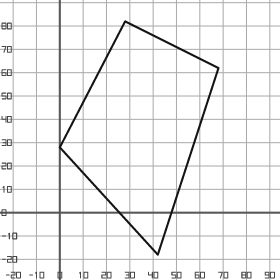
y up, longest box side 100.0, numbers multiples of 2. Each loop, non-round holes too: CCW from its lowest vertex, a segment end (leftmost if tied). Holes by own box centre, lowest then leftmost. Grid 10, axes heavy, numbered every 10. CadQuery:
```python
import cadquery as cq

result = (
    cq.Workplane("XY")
    .moveTo(42.0, -18.0)
    .lineTo(68.0, 62.0)
    .lineTo(28.0, 82.0)
    .lineTo(0.0, 28.0)
    .close()
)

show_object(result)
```